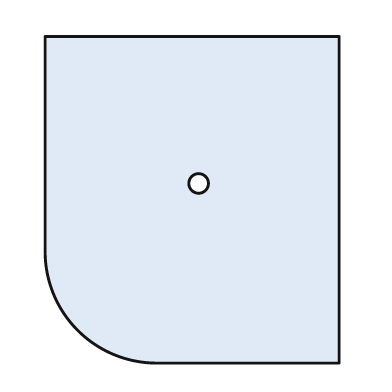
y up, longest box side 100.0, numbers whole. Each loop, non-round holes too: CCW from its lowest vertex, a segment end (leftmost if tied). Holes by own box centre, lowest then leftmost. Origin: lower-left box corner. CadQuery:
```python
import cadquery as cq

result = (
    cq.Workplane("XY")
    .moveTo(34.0, 0.0)
    .lineTo(90.0, 0.0)
    .lineTo(90.0, 100.0)
    .lineTo(0.0, 100.0)
    .lineTo(0.0, 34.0)
    .threePointArc((10.0, 10.0), (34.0, 0.0))
    .close()
    .moveTo(47.0, 55.0)
    .circle(3.0)
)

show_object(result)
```